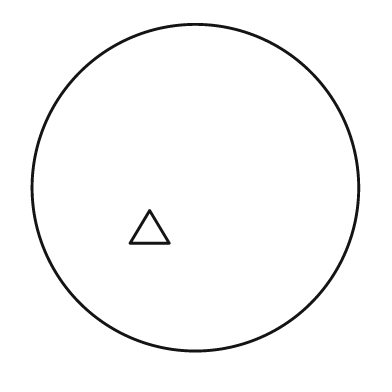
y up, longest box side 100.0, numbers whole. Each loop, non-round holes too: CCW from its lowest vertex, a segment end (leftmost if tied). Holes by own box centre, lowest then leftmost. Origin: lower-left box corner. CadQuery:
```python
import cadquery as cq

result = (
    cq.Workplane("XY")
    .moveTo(50.0, 50.0)
    .circle(50.0)
    .moveTo(30.0, 33.0)
    .lineTo(42.0, 33.0)
    .lineTo(36.0, 43.0)
    .close()
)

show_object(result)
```